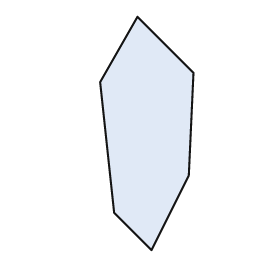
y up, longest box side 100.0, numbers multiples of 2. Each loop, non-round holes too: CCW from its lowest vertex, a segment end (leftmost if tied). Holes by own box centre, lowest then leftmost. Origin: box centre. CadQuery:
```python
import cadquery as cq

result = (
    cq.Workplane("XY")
    .moveTo(2.0, -50.0)
    .lineTo(18.0, -18.0)
    .lineTo(20.0, 26.0)
    .lineTo(-4.0, 50.0)
    .lineTo(-20.0, 22.0)
    .lineTo(-14.0, -34.0)
    .close()
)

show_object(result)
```